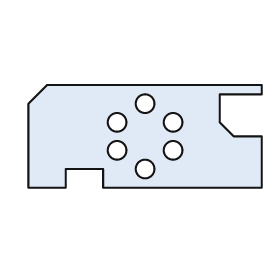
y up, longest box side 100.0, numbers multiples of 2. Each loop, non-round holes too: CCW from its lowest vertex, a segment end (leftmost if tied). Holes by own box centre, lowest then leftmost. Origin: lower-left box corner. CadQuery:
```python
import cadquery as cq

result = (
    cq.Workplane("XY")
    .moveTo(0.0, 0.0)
    .lineTo(16.0, 0.0)
    .lineTo(16.0, 8.0)
    .lineTo(32.0, 8.0)
    .lineTo(32.0, 0.0)
    .lineTo(100.0, 0.0)
    .lineTo(100.0, 22.0)
    .lineTo(88.0, 22.0)
    .lineTo(82.0, 28.0)
    .lineTo(82.0, 40.0)
    .lineTo(100.0, 40.0)
    .lineTo(100.0, 44.0)
    .lineTo(8.0, 44.0)
    .lineTo(0.0, 36.0)
    .close()
    .moveTo(50.0, 8.0)
    .circle(4.0)
    .moveTo(38.0, 16.0)
    .circle(4.0)
    .moveTo(62.0, 16.0)
    .circle(4.0)
    .moveTo(38.0, 28.0)
    .circle(4.0)
    .moveTo(62.0, 28.0)
    .circle(4.0)
    .moveTo(50.0, 36.0)
    .circle(4.0)
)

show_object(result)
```